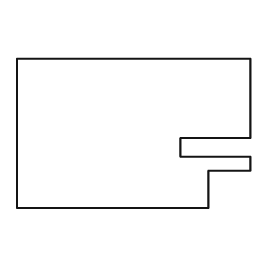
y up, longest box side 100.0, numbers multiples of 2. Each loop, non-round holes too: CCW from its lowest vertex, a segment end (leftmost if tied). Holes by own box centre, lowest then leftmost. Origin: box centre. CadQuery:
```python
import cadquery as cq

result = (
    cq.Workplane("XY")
    .moveTo(-50.0, -32.0)
    .lineTo(32.0, -32.0)
    .lineTo(32.0, -16.0)
    .lineTo(50.0, -16.0)
    .lineTo(50.0, -10.0)
    .lineTo(20.0, -10.0)
    .lineTo(20.0, -2.0)
    .lineTo(50.0, -2.0)
    .lineTo(50.0, 32.0)
    .lineTo(-50.0, 32.0)
    .close()
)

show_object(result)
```